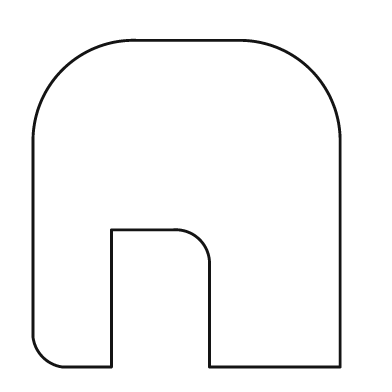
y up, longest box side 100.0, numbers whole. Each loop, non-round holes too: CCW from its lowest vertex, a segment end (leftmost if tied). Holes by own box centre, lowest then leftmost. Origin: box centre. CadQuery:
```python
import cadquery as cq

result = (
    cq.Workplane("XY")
    .moveTo(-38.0, -50.0)
    .lineTo(-23.0, -50.0)
    .lineTo(-23.0, -8.0)
    .lineTo(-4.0, -8.0)
    .threePointArc((4.0, -11.0), (7.0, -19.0))
    .lineTo(7.0, -50.0)
    .lineTo(47.0, -50.0)
    .lineTo(47.0, 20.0)
    .threePointArc((38.0, 41.0), (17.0, 50.0))
    .lineTo(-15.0, 50.0)
    .threePointArc((-38.0, 41.0), (-47.0, 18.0))
    .lineTo(-47.0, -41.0)
    .threePointArc((-44.0, -47.0), (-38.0, -50.0))
    .close()
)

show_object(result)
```